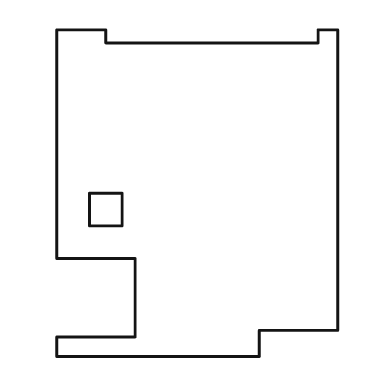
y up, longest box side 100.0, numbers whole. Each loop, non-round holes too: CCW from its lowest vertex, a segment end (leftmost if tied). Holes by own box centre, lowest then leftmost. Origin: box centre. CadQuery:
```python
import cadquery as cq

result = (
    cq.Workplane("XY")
    .moveTo(-43.0, -50.0)
    .lineTo(19.0, -50.0)
    .lineTo(19.0, -42.0)
    .lineTo(43.0, -42.0)
    .lineTo(43.0, 50.0)
    .lineTo(37.0, 50.0)
    .lineTo(37.0, 46.0)
    .lineTo(-28.0, 46.0)
    .lineTo(-28.0, 50.0)
    .lineTo(-43.0, 50.0)
    .lineTo(-43.0, -20.0)
    .lineTo(-19.0, -20.0)
    .lineTo(-19.0, -44.0)
    .lineTo(-43.0, -44.0)
    .close()
    .moveTo(-33.0, -10.0)
    .lineTo(-23.0, -10.0)
    .lineTo(-23.0, 0.0)
    .lineTo(-33.0, 0.0)
    .close()
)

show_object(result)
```